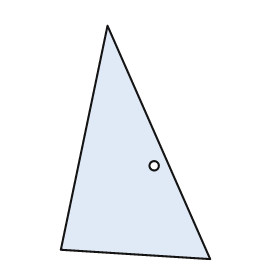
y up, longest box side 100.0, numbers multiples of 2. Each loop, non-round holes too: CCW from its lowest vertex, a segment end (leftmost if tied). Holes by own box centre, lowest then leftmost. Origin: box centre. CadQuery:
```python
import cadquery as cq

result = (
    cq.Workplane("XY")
    .moveTo(32.0, -50.0)
    .lineTo(-12.0, 50.0)
    .lineTo(-32.0, -46.0)
    .close()
    .moveTo(8.0, -10.0)
    .circle(2.0)
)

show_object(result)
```